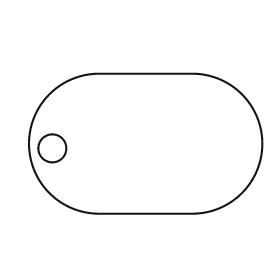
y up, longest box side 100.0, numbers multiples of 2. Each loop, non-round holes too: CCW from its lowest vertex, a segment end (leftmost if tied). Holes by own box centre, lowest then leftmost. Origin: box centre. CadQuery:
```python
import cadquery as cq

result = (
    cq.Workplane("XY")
    .moveTo(-20.0, -30.0)
    .lineTo(20.0, -30.0)
    .threePointArc((50.0, 0.0), (20.0, 30.0))
    .lineTo(-20.0, 30.0)
    .threePointArc((-50.0, 0.0), (-20.0, -30.0))
    .close()
    .moveTo(-40.0, -2.0)
    .circle(6.0)
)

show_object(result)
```